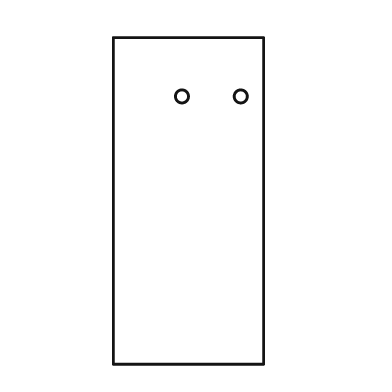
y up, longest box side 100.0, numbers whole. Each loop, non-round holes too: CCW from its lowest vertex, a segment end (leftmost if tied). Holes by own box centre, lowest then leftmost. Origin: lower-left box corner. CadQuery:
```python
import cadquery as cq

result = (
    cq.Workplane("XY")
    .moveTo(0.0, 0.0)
    .lineTo(46.0, 0.0)
    .lineTo(46.0, 100.0)
    .lineTo(0.0, 100.0)
    .close()
    .moveTo(21.0, 82.0)
    .circle(2.0)
    .moveTo(39.0, 82.0)
    .circle(2.0)
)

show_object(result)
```